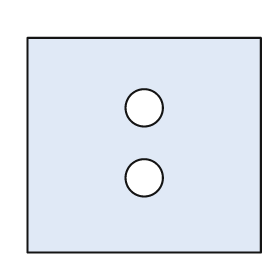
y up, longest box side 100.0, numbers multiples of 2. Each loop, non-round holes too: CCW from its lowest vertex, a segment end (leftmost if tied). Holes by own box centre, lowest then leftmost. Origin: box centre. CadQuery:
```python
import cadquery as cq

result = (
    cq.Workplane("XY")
    .moveTo(-50.0, -46.0)
    .lineTo(50.0, -46.0)
    .lineTo(50.0, 46.0)
    .lineTo(-50.0, 46.0)
    .close()
    .moveTo(0.0, -14.0)
    .circle(8.0)
    .moveTo(0.0, 16.0)
    .circle(8.0)
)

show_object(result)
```